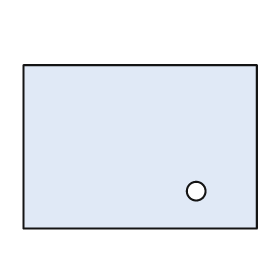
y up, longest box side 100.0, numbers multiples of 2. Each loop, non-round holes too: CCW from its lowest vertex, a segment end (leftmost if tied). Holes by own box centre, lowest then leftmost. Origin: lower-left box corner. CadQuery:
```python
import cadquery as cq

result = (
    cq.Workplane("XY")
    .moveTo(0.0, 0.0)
    .lineTo(100.0, 0.0)
    .lineTo(100.0, 70.0)
    .lineTo(0.0, 70.0)
    .close()
    .moveTo(74.0, 16.0)
    .circle(4.0)
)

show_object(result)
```